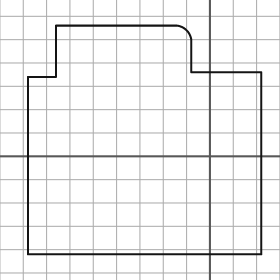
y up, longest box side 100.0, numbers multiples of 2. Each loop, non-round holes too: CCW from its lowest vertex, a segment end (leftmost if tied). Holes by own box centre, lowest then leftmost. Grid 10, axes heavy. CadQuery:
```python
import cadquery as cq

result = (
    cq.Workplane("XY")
    .moveTo(-78.0, -42.0)
    .lineTo(22.0, -42.0)
    .lineTo(22.0, 36.0)
    .lineTo(-8.0, 36.0)
    .lineTo(-8.0, 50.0)
    .threePointArc((-10.0, 54.0), (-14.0, 56.0))
    .lineTo(-66.0, 56.0)
    .lineTo(-66.0, 34.0)
    .lineTo(-78.0, 34.0)
    .close()
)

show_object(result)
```